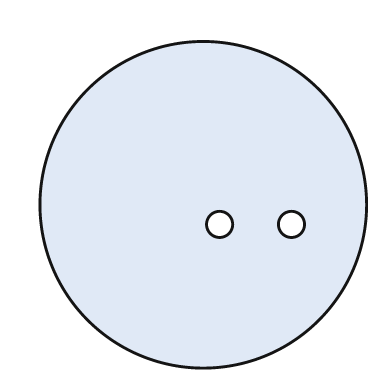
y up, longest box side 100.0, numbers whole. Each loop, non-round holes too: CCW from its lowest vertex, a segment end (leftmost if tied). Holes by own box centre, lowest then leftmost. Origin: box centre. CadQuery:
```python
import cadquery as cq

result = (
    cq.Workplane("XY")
    .moveTo(0.0, 0.0)
    .circle(50.0)
    .moveTo(5.0, -6.0)
    .circle(4.0)
    .moveTo(27.0, -6.0)
    .circle(4.0)
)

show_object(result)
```